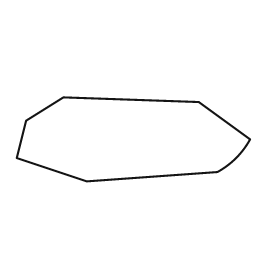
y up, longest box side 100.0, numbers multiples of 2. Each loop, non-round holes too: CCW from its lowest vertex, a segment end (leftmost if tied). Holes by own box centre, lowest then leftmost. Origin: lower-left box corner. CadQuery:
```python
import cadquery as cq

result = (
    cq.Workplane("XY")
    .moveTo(30.0, 0.0)
    .lineTo(86.0, 4.0)
    .threePointArc((94.0, 10.0), (100.0, 18.0))
    .lineTo(78.0, 34.0)
    .lineTo(20.0, 36.0)
    .lineTo(4.0, 26.0)
    .lineTo(0.0, 10.0)
    .close()
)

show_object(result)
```